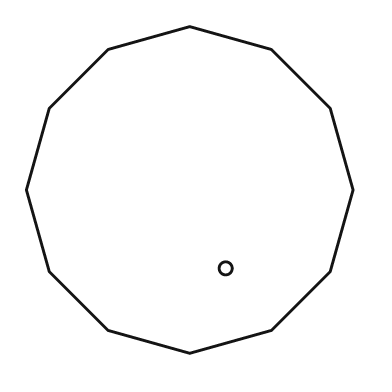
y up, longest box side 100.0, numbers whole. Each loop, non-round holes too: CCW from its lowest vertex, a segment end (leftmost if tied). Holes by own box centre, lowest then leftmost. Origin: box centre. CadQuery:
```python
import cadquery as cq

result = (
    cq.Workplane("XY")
    .moveTo(0.0, -50.0)
    .lineTo(25.0, -43.0)
    .lineTo(43.0, -25.0)
    .lineTo(50.0, 0.0)
    .lineTo(43.0, 25.0)
    .lineTo(25.0, 43.0)
    .lineTo(0.0, 50.0)
    .lineTo(-25.0, 43.0)
    .lineTo(-43.0, 25.0)
    .lineTo(-50.0, 0.0)
    .lineTo(-43.0, -25.0)
    .lineTo(-25.0, -43.0)
    .close()
    .moveTo(11.0, -24.0)
    .circle(2.0)
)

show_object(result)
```